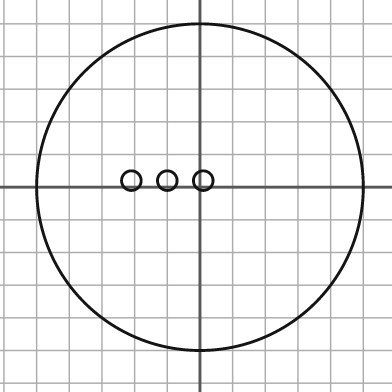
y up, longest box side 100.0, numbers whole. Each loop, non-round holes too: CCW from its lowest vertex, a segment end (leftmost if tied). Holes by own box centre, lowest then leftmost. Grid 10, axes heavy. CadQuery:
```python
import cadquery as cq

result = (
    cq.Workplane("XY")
    .moveTo(0.0, 0.0)
    .circle(50.0)
    .moveTo(-21.0, 2.0)
    .circle(3.0)
    .moveTo(-10.0, 2.0)
    .circle(3.0)
    .moveTo(1.0, 2.0)
    .circle(3.0)
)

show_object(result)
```